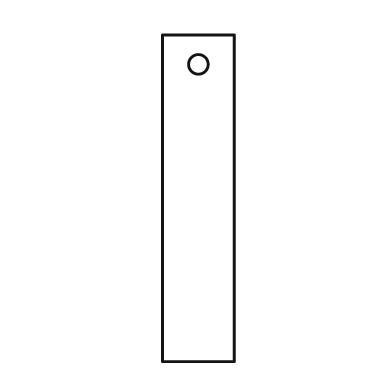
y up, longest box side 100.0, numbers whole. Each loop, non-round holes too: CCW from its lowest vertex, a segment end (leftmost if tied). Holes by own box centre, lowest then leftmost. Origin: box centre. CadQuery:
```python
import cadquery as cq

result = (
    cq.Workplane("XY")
    .moveTo(-11.0, -50.0)
    .lineTo(11.0, -50.0)
    .lineTo(11.0, 50.0)
    .lineTo(-11.0, 50.0)
    .close()
    .moveTo(0.0, 41.0)
    .circle(3.0)
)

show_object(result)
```